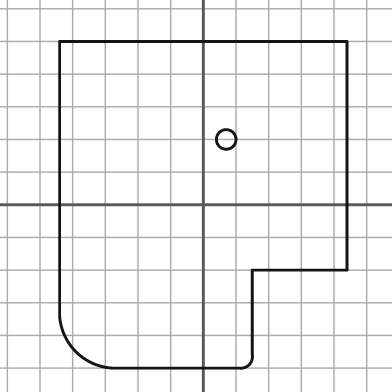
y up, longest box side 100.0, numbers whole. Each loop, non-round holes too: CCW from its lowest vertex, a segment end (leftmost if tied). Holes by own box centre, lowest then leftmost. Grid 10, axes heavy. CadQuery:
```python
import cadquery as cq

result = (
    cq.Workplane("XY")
    .moveTo(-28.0, -50.0)
    .lineTo(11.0, -50.0)
    .threePointArc((14.0, -49.0), (15.0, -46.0))
    .lineTo(15.0, -20.0)
    .lineTo(44.0, -20.0)
    .lineTo(44.0, 50.0)
    .lineTo(-44.0, 50.0)
    .lineTo(-44.0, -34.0)
    .threePointArc((-39.0, -45.0), (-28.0, -50.0))
    .close()
    .moveTo(7.0, 20.0)
    .circle(3.0)
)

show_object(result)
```